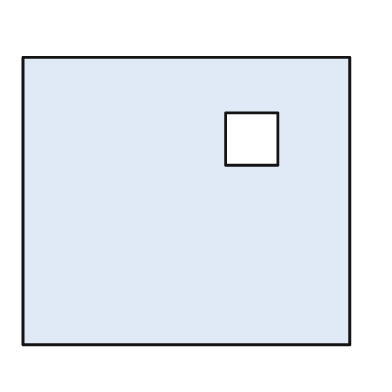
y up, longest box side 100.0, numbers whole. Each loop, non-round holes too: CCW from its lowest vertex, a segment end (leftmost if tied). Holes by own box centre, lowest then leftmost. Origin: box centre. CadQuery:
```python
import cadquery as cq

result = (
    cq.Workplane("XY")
    .moveTo(-50.0, -44.0)
    .lineTo(50.0, -44.0)
    .lineTo(50.0, 44.0)
    .lineTo(-50.0, 44.0)
    .close()
    .moveTo(12.0, 11.0)
    .lineTo(28.0, 11.0)
    .lineTo(28.0, 27.0)
    .lineTo(12.0, 27.0)
    .close()
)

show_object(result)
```